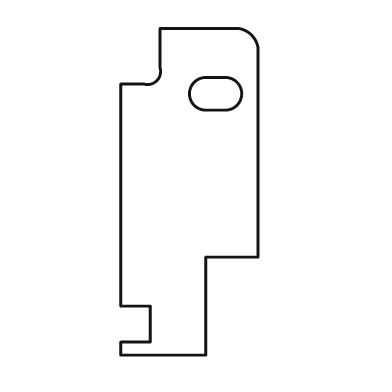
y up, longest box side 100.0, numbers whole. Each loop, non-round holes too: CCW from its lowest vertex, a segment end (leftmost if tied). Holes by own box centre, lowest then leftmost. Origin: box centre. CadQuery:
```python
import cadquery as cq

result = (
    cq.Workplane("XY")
    .moveTo(-21.0, -50.0)
    .lineTo(5.0, -50.0)
    .lineTo(5.0, -20.0)
    .lineTo(21.0, -20.0)
    .lineTo(21.0, 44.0)
    .threePointArc((19.0, 48.0), (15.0, 50.0))
    .lineTo(-9.0, 50.0)
    .lineTo(-9.0, 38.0)
    .threePointArc((-10.0, 34.0), (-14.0, 33.0))
    .lineTo(-21.0, 33.0)
    .lineTo(-21.0, -35.0)
    .lineTo(-12.0, -35.0)
    .lineTo(-12.0, -46.0)
    .lineTo(-21.0, -46.0)
    .close()
    .moveTo(5.0, 25.0)
    .lineTo(11.0, 25.0)
    .threePointArc((16.0, 30.0), (11.0, 35.0))
    .lineTo(5.0, 35.0)
    .threePointArc((0.0, 30.0), (5.0, 25.0))
    .close()
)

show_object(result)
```